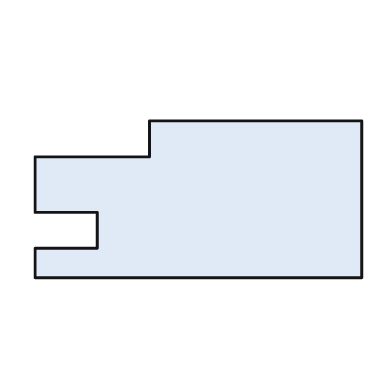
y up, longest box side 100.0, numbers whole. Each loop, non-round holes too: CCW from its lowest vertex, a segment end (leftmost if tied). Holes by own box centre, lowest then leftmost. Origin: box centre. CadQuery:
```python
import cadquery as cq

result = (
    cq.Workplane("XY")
    .moveTo(-50.0, -24.0)
    .lineTo(50.0, -24.0)
    .lineTo(50.0, 24.0)
    .lineTo(-15.0, 24.0)
    .lineTo(-15.0, 13.0)
    .lineTo(-50.0, 13.0)
    .lineTo(-50.0, -4.0)
    .lineTo(-31.0, -4.0)
    .lineTo(-31.0, -15.0)
    .lineTo(-50.0, -15.0)
    .close()
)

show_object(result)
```